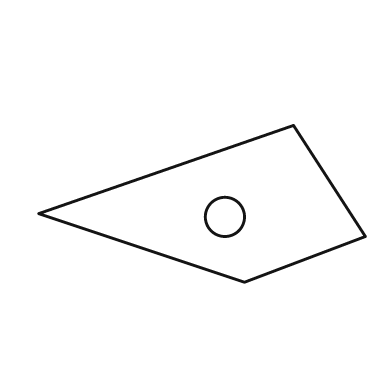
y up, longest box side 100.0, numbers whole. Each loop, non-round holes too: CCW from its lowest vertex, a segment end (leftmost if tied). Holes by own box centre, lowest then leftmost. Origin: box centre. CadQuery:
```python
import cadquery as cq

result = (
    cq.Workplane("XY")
    .moveTo(13.0, -24.0)
    .lineTo(50.0, -10.0)
    .lineTo(28.0, 24.0)
    .lineTo(-50.0, -3.0)
    .close()
    .moveTo(7.0, -4.0)
    .circle(6.0)
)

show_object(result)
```